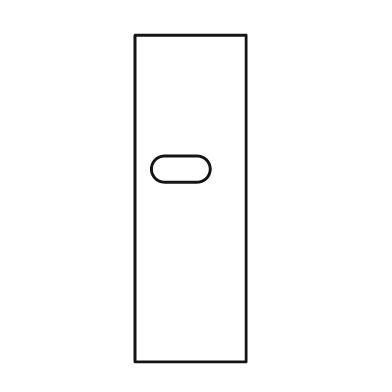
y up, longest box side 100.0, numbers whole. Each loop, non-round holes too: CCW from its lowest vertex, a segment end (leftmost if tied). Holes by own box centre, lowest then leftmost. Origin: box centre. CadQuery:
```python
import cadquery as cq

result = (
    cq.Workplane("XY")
    .moveTo(-17.0, -50.0)
    .lineTo(17.0, -50.0)
    .lineTo(17.0, 50.0)
    .lineTo(-17.0, 50.0)
    .close()
    .moveTo(-8.0, 5.0)
    .lineTo(2.0, 5.0)
    .threePointArc((6.0, 9.0), (2.0, 13.0))
    .lineTo(-8.0, 13.0)
    .threePointArc((-12.0, 9.0), (-8.0, 5.0))
    .close()
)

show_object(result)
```